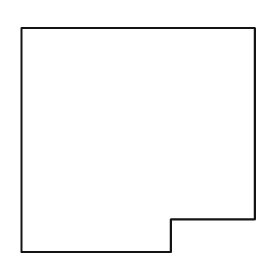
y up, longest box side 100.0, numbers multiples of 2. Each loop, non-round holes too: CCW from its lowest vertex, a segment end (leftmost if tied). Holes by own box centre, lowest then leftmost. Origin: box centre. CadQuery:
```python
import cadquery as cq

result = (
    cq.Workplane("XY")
    .moveTo(-50.0, -48.0)
    .lineTo(14.0, -48.0)
    .lineTo(14.0, -34.0)
    .lineTo(50.0, -34.0)
    .lineTo(50.0, 48.0)
    .lineTo(-50.0, 48.0)
    .close()
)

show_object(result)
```